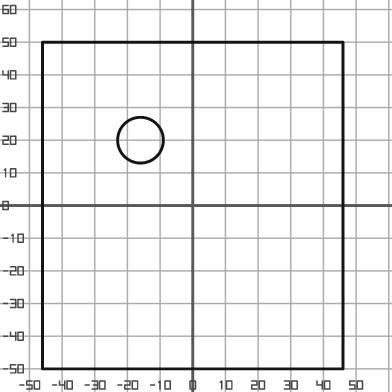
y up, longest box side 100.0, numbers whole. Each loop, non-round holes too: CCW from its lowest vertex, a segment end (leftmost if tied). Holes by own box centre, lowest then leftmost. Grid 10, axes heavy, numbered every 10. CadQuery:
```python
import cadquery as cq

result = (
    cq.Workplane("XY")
    .moveTo(-46.0, -50.0)
    .lineTo(46.0, -50.0)
    .lineTo(46.0, 50.0)
    .lineTo(-46.0, 50.0)
    .close()
    .moveTo(-16.0, 20.0)
    .circle(7.0)
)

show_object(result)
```